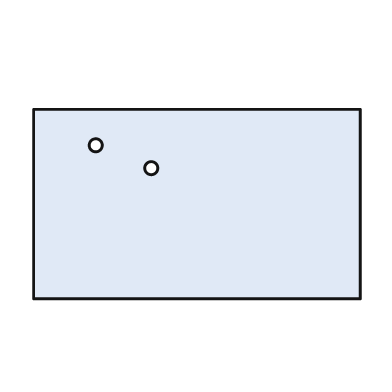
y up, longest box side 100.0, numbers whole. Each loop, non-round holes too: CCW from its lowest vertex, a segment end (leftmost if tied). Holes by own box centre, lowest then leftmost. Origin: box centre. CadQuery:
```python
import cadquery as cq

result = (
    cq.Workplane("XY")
    .moveTo(-50.0, -29.0)
    .lineTo(50.0, -29.0)
    .lineTo(50.0, 29.0)
    .lineTo(-50.0, 29.0)
    .close()
    .moveTo(-14.0, 11.0)
    .circle(2.0)
    .moveTo(-31.0, 18.0)
    .circle(2.0)
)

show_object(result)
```